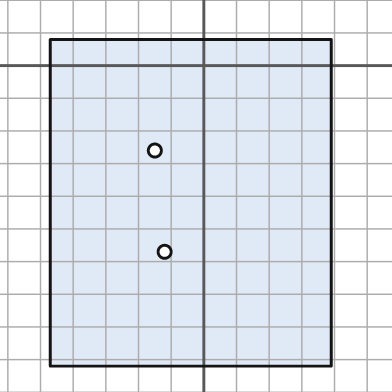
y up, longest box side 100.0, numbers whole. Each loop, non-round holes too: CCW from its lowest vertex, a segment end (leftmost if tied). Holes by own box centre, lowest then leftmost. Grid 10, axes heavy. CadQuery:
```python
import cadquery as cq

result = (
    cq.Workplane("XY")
    .moveTo(-47.0, -92.0)
    .lineTo(39.0, -92.0)
    .lineTo(39.0, 8.0)
    .lineTo(-47.0, 8.0)
    .close()
    .moveTo(-12.0, -57.0)
    .circle(2.0)
    .moveTo(-15.0, -26.0)
    .circle(2.0)
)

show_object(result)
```